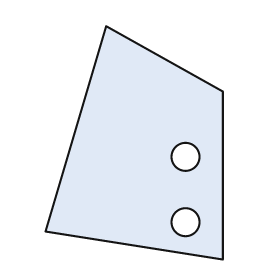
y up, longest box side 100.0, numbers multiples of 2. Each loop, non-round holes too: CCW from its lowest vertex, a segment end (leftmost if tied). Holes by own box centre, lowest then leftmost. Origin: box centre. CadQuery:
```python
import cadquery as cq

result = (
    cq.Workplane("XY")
    .moveTo(38.0, -50.0)
    .lineTo(38.0, 22.0)
    .lineTo(-12.0, 50.0)
    .lineTo(-38.0, -38.0)
    .close()
    .moveTo(22.0, -34.0)
    .circle(6.0)
    .moveTo(22.0, -6.0)
    .circle(6.0)
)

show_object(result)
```